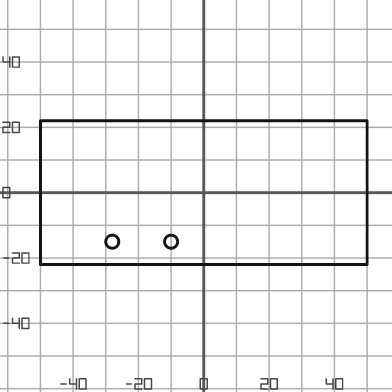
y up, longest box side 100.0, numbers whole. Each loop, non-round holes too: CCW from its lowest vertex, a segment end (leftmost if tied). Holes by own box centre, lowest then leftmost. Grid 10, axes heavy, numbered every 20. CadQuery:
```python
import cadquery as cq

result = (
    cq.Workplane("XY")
    .moveTo(-50.0, -22.0)
    .lineTo(50.0, -22.0)
    .lineTo(50.0, 22.0)
    .lineTo(-50.0, 22.0)
    .close()
    .moveTo(-28.0, -15.0)
    .circle(2.0)
    .moveTo(-10.0, -15.0)
    .circle(2.0)
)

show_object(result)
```